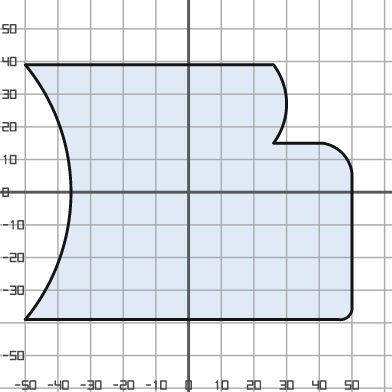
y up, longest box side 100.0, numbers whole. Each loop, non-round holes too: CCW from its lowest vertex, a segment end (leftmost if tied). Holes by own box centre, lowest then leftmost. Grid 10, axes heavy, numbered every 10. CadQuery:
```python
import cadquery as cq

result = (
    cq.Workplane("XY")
    .moveTo(-50.0, -39.0)
    .lineTo(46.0, -39.0)
    .threePointArc((49.0, -38.0), (50.0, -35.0))
    .lineTo(50.0, 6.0)
    .threePointArc((47.0, 12.0), (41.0, 15.0))
    .lineTo(26.0, 15.0)
    .threePointArc((30.0, 27.0), (26.0, 39.0))
    .lineTo(-50.0, 39.0)
    .threePointArc((-36.0, 0.0), (-50.0, -39.0))
    .close()
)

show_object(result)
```